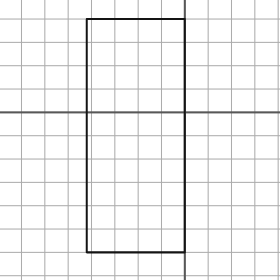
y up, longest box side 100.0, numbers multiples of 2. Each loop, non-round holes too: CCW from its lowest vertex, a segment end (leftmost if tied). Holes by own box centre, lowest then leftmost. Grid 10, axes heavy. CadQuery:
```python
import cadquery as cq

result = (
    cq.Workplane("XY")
    .moveTo(-42.0, -60.0)
    .lineTo(0.0, -60.0)
    .lineTo(0.0, 40.0)
    .lineTo(-42.0, 40.0)
    .close()
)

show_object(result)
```